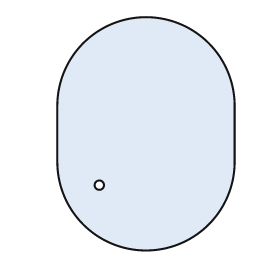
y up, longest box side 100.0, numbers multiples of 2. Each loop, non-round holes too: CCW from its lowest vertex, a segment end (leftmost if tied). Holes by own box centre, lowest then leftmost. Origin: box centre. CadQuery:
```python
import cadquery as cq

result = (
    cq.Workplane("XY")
    .moveTo(-38.0, -12.0)
    .threePointArc((0.0, -50.0), (38.0, -12.0))
    .lineTo(38.0, 12.0)
    .threePointArc((0.0, 50.0), (-38.0, 12.0))
    .close()
    .moveTo(-20.0, -22.0)
    .circle(2.0)
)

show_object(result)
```